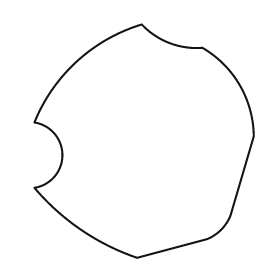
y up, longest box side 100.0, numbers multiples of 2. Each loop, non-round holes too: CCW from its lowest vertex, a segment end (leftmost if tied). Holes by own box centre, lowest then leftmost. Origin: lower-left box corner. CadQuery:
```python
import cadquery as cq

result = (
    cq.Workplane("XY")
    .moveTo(44.0, 0.0)
    .lineTo(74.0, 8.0)
    .threePointArc((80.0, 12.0), (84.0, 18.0))
    .lineTo(94.0, 52.0)
    .threePointArc((88.0, 74.0), (72.0, 90.0))
    .threePointArc((58.0, 92.0), (46.0, 100.0))
    .threePointArc((18.0, 84.0), (0.0, 58.0))
    .threePointArc((12.0, 44.0), (0.0, 30.0))
    .threePointArc((20.0, 12.0), (44.0, 0.0))
    .close()
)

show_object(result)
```